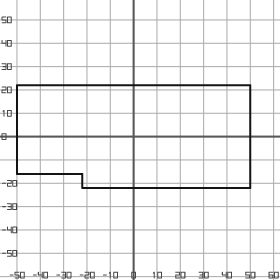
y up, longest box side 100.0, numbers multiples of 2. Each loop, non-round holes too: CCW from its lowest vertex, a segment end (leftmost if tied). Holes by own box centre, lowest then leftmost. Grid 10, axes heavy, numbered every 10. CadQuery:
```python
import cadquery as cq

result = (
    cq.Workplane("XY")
    .moveTo(-22.0, -22.0)
    .lineTo(50.0, -22.0)
    .lineTo(50.0, 22.0)
    .lineTo(-50.0, 22.0)
    .lineTo(-50.0, -16.0)
    .lineTo(-22.0, -16.0)
    .close()
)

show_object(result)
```